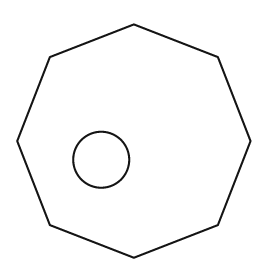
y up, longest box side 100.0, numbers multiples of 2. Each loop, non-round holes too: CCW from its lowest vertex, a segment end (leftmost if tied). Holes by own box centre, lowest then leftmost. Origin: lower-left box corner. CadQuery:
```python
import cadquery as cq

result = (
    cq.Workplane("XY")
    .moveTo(50.0, 0.0)
    .lineTo(86.0, 14.0)
    .lineTo(100.0, 50.0)
    .lineTo(86.0, 86.0)
    .lineTo(50.0, 100.0)
    .lineTo(14.0, 86.0)
    .lineTo(0.0, 50.0)
    .lineTo(14.0, 14.0)
    .close()
    .moveTo(36.0, 42.0)
    .circle(12.0)
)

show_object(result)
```